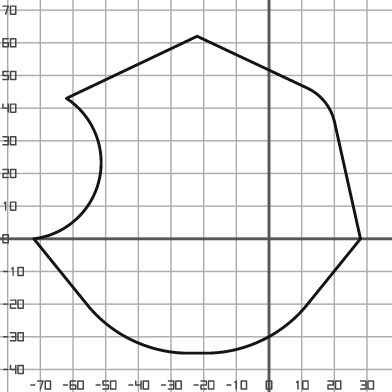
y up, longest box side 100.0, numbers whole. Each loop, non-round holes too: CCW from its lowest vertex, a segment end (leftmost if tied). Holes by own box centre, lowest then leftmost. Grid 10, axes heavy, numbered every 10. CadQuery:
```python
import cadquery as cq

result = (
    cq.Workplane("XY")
    .moveTo(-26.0, -35.0)
    .lineTo(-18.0, -35.0)
    .threePointArc((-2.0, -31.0), (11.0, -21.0))
    .lineTo(28.0, 0.0)
    .lineTo(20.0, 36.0)
    .threePointArc((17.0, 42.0), (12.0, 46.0))
    .lineTo(-22.0, 62.0)
    .lineTo(-62.0, 43.0)
    .threePointArc((-52.0, 18.0), (-72.0, 0.0))
    .lineTo(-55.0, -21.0)
    .threePointArc((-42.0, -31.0), (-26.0, -35.0))
    .close()
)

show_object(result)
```